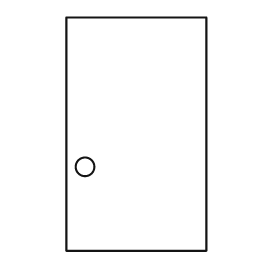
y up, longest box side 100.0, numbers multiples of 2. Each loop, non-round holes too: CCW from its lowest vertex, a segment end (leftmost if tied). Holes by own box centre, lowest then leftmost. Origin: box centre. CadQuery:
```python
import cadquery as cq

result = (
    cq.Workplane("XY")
    .moveTo(-30.0, -50.0)
    .lineTo(30.0, -50.0)
    .lineTo(30.0, 50.0)
    .lineTo(-30.0, 50.0)
    .close()
    .moveTo(-22.0, -14.0)
    .circle(4.0)
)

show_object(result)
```